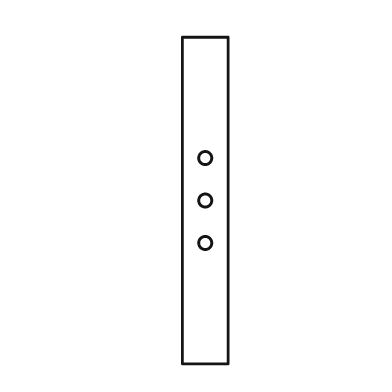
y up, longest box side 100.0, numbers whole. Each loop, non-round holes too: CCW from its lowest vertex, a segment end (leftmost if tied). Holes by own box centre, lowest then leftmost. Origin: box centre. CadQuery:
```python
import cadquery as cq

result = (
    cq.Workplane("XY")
    .moveTo(-7.0, -50.0)
    .lineTo(7.0, -50.0)
    .lineTo(7.0, 50.0)
    .lineTo(-7.0, 50.0)
    .close()
    .moveTo(0.0, -13.0)
    .circle(2.0)
    .moveTo(0.0, 0.0)
    .circle(2.0)
    .moveTo(0.0, 13.0)
    .circle(2.0)
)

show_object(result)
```